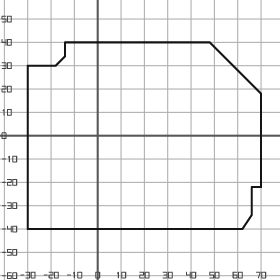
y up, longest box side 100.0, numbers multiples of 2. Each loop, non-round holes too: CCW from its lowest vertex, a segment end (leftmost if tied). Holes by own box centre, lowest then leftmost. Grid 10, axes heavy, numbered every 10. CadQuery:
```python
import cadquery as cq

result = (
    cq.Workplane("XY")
    .moveTo(-30.0, -40.0)
    .lineTo(62.0, -40.0)
    .lineTo(66.0, -34.0)
    .lineTo(66.0, -22.0)
    .lineTo(70.0, -22.0)
    .lineTo(70.0, 18.0)
    .lineTo(48.0, 40.0)
    .lineTo(-14.0, 40.0)
    .lineTo(-14.0, 34.0)
    .lineTo(-18.0, 30.0)
    .lineTo(-30.0, 30.0)
    .close()
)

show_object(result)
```